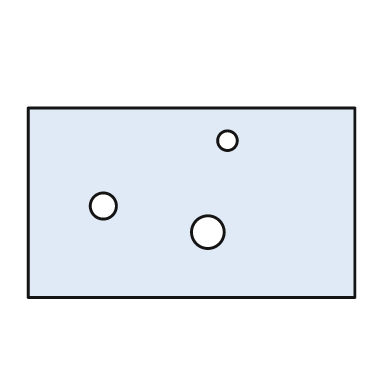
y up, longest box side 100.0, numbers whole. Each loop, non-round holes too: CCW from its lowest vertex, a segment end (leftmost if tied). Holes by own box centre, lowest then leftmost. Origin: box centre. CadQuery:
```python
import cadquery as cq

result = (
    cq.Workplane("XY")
    .moveTo(-50.0, -29.0)
    .lineTo(50.0, -29.0)
    .lineTo(50.0, 29.0)
    .lineTo(-50.0, 29.0)
    .close()
    .moveTo(5.0, -9.0)
    .circle(5.0)
    .moveTo(-27.0, -1.0)
    .circle(4.0)
    .moveTo(11.0, 19.0)
    .circle(3.0)
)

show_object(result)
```